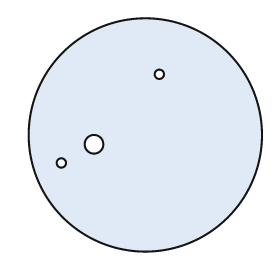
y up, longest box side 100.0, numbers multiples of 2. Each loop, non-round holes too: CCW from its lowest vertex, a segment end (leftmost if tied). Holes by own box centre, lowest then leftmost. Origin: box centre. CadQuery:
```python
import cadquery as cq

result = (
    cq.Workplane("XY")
    .moveTo(0.0, 0.0)
    .circle(50.0)
    .moveTo(-36.0, -12.0)
    .circle(2.0)
    .moveTo(-22.0, -4.0)
    .circle(4.0)
    .moveTo(6.0, 26.0)
    .circle(2.0)
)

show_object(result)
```